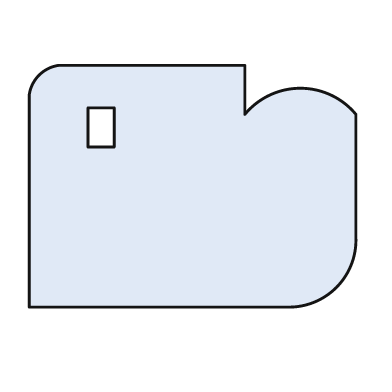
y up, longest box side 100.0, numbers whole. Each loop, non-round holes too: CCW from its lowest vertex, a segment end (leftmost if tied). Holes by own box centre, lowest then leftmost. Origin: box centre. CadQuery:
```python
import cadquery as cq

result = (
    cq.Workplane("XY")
    .moveTo(-50.0, -37.0)
    .lineTo(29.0, -37.0)
    .threePointArc((44.0, -31.0), (50.0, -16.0))
    .lineTo(50.0, 22.0)
    .threePointArc((33.0, 30.0), (16.0, 22.0))
    .lineTo(16.0, 37.0)
    .lineTo(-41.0, 37.0)
    .threePointArc((-47.0, 34.0), (-50.0, 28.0))
    .close()
    .moveTo(-32.0, 12.0)
    .lineTo(-24.0, 12.0)
    .lineTo(-24.0, 24.0)
    .lineTo(-32.0, 24.0)
    .close()
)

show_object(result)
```